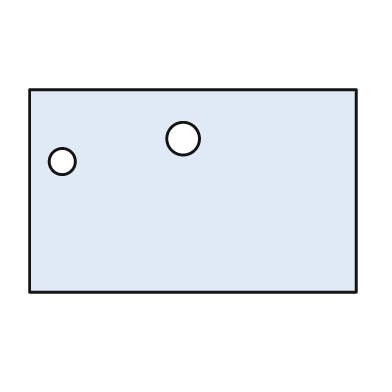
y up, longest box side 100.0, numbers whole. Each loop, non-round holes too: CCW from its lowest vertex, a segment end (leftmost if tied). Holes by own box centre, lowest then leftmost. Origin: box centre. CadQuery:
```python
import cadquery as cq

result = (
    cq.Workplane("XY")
    .moveTo(-50.0, -31.0)
    .lineTo(50.0, -31.0)
    .lineTo(50.0, 31.0)
    .lineTo(-50.0, 31.0)
    .close()
    .moveTo(-40.0, 9.0)
    .circle(4.0)
    .moveTo(-3.0, 16.0)
    .circle(5.0)
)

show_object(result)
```